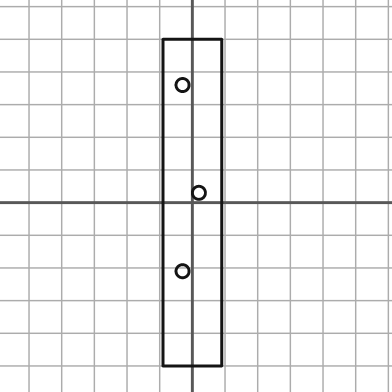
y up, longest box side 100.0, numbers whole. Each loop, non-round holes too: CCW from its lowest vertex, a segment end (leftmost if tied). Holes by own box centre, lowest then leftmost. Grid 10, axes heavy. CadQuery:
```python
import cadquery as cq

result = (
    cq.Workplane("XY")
    .moveTo(-9.0, -50.0)
    .lineTo(9.0, -50.0)
    .lineTo(9.0, 50.0)
    .lineTo(-9.0, 50.0)
    .close()
    .moveTo(-3.0, -21.0)
    .circle(2.0)
    .moveTo(2.0, 3.0)
    .circle(2.0)
    .moveTo(-3.0, 36.0)
    .circle(2.0)
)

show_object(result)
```